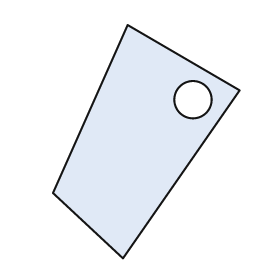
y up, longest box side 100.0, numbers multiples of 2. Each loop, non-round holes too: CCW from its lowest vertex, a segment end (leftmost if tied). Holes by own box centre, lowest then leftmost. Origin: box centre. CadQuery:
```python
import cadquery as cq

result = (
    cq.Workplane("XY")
    .moveTo(-10.0, -50.0)
    .lineTo(40.0, 22.0)
    .lineTo(-8.0, 50.0)
    .lineTo(-40.0, -22.0)
    .close()
    .moveTo(20.0, 18.0)
    .circle(8.0)
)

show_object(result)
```